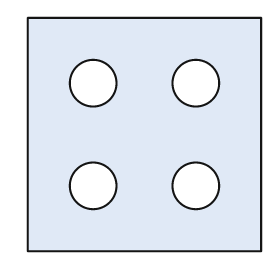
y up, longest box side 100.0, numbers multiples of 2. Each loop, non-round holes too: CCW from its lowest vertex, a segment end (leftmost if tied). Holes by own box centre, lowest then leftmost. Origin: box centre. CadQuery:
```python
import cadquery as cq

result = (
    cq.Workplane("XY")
    .moveTo(-50.0, -50.0)
    .lineTo(50.0, -50.0)
    .lineTo(50.0, 50.0)
    .lineTo(-50.0, 50.0)
    .close()
    .moveTo(-22.0, -22.0)
    .circle(10.0)
    .moveTo(22.0, -22.0)
    .circle(10.0)
    .moveTo(-22.0, 22.0)
    .circle(10.0)
    .moveTo(22.0, 22.0)
    .circle(10.0)
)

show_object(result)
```